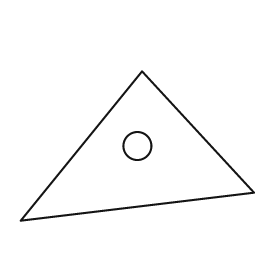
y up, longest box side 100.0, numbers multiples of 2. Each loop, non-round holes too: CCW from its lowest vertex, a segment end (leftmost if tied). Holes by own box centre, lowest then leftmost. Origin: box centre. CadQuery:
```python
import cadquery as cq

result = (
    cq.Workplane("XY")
    .moveTo(-50.0, -32.0)
    .lineTo(50.0, -20.0)
    .lineTo(2.0, 32.0)
    .close()
    .moveTo(0.0, 0.0)
    .circle(6.0)
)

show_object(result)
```